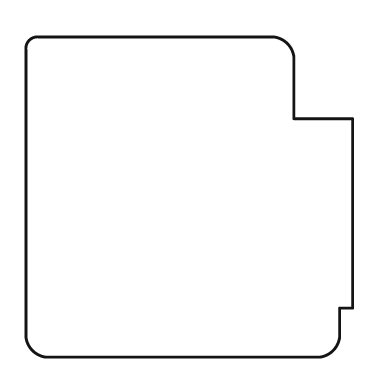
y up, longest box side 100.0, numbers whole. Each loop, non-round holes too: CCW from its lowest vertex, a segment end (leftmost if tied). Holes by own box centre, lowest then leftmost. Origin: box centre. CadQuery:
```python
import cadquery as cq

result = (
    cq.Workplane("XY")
    .moveTo(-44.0, -49.0)
    .lineTo(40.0, -49.0)
    .threePointArc((44.0, -47.0), (46.0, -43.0))
    .lineTo(46.0, -34.0)
    .lineTo(50.0, -34.0)
    .lineTo(50.0, 24.0)
    .lineTo(32.0, 24.0)
    .lineTo(32.0, 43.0)
    .threePointArc((30.0, 47.0), (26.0, 49.0))
    .lineTo(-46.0, 49.0)
    .threePointArc((-49.0, 48.0), (-50.0, 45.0))
    .lineTo(-50.0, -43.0)
    .threePointArc((-48.0, -47.0), (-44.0, -49.0))
    .close()
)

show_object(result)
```